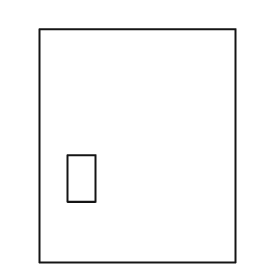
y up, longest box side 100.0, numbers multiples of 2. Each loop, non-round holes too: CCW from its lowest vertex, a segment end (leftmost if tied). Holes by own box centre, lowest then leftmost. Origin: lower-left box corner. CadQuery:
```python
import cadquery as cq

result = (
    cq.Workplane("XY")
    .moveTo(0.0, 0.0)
    .lineTo(84.0, 0.0)
    .lineTo(84.0, 100.0)
    .lineTo(0.0, 100.0)
    .close()
    .moveTo(12.0, 26.0)
    .lineTo(24.0, 26.0)
    .lineTo(24.0, 46.0)
    .lineTo(12.0, 46.0)
    .close()
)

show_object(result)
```